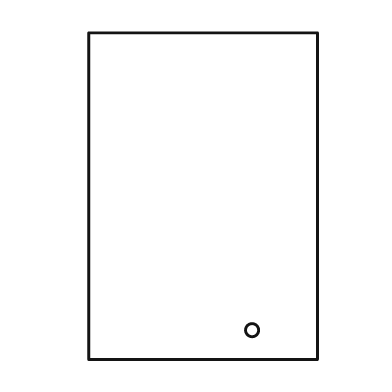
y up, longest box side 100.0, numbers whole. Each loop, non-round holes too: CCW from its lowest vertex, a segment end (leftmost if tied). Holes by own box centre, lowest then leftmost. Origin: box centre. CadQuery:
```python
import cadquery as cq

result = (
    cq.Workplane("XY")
    .moveTo(-35.0, -50.0)
    .lineTo(35.0, -50.0)
    .lineTo(35.0, 50.0)
    .lineTo(-35.0, 50.0)
    .close()
    .moveTo(15.0, -41.0)
    .circle(2.0)
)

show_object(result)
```